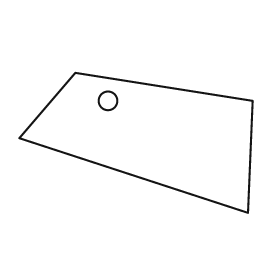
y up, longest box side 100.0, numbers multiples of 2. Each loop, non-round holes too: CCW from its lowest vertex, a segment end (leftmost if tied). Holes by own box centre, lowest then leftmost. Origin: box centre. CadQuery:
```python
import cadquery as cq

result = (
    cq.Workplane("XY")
    .moveTo(48.0, -30.0)
    .lineTo(50.0, 18.0)
    .lineTo(-26.0, 30.0)
    .lineTo(-50.0, 2.0)
    .close()
    .moveTo(-12.0, 18.0)
    .circle(4.0)
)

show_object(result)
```